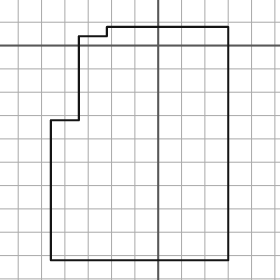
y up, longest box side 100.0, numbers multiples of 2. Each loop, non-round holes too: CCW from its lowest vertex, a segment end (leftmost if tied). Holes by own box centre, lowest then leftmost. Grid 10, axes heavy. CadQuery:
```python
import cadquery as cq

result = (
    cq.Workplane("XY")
    .moveTo(-46.0, -92.0)
    .lineTo(30.0, -92.0)
    .lineTo(30.0, 8.0)
    .lineTo(-22.0, 8.0)
    .lineTo(-22.0, 4.0)
    .lineTo(-34.0, 4.0)
    .lineTo(-34.0, -32.0)
    .lineTo(-46.0, -32.0)
    .close()
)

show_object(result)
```